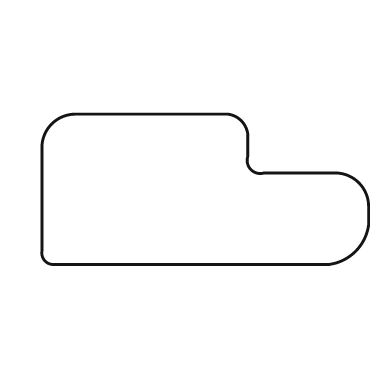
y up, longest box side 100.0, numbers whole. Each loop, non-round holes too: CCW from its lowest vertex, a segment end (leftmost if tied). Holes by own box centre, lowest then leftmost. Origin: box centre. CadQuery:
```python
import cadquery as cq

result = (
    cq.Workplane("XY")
    .moveTo(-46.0, -23.0)
    .lineTo(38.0, -23.0)
    .threePointArc((46.0, -19.0), (50.0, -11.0))
    .lineTo(50.0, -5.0)
    .threePointArc((47.0, 2.0), (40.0, 5.0))
    .lineTo(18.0, 5.0)
    .threePointArc((14.0, 6.0), (13.0, 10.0))
    .lineTo(13.0, 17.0)
    .threePointArc((11.0, 21.0), (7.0, 23.0))
    .lineTo(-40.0, 23.0)
    .threePointArc((-47.0, 20.0), (-50.0, 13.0))
    .lineTo(-50.0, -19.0)
    .threePointArc((-49.0, -22.0), (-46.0, -23.0))
    .close()
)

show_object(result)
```